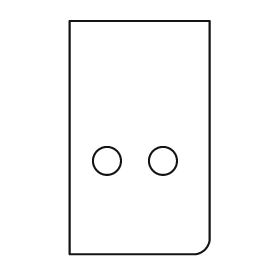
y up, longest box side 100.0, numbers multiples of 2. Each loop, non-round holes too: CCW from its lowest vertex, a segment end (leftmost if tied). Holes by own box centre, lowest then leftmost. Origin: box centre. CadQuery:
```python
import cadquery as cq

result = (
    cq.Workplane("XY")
    .moveTo(-30.0, -50.0)
    .lineTo(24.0, -50.0)
    .threePointArc((28.0, -48.0), (30.0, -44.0))
    .lineTo(30.0, 50.0)
    .lineTo(-30.0, 50.0)
    .close()
    .moveTo(-14.0, -10.0)
    .circle(6.0)
    .moveTo(10.0, -10.0)
    .circle(6.0)
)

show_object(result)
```